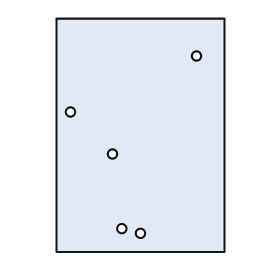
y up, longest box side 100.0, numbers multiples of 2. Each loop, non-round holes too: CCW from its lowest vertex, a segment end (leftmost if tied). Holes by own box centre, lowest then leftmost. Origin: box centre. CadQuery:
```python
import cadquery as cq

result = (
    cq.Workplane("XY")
    .moveTo(-36.0, -50.0)
    .lineTo(36.0, -50.0)
    .lineTo(36.0, 50.0)
    .lineTo(-36.0, 50.0)
    .close()
    .moveTo(0.0, -42.0)
    .circle(2.0)
    .moveTo(-8.0, -40.0)
    .circle(2.0)
    .moveTo(-12.0, -8.0)
    .circle(2.0)
    .moveTo(-30.0, 10.0)
    .circle(2.0)
    .moveTo(24.0, 34.0)
    .circle(2.0)
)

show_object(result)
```